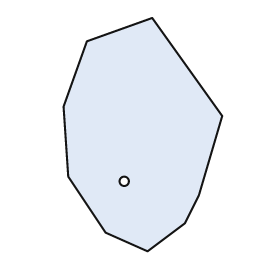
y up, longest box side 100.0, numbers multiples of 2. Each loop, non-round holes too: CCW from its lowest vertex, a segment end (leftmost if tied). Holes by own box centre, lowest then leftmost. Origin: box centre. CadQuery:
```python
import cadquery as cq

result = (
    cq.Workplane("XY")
    .moveTo(2.0, -50.0)
    .lineTo(18.0, -38.0)
    .lineTo(24.0, -26.0)
    .lineTo(34.0, 8.0)
    .lineTo(4.0, 50.0)
    .lineTo(-24.0, 40.0)
    .lineTo(-34.0, 12.0)
    .lineTo(-32.0, -18.0)
    .lineTo(-16.0, -42.0)
    .close()
    .moveTo(-8.0, -20.0)
    .circle(2.0)
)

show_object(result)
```